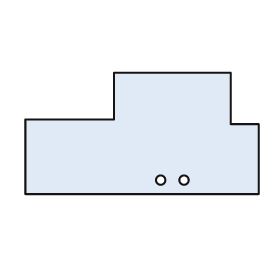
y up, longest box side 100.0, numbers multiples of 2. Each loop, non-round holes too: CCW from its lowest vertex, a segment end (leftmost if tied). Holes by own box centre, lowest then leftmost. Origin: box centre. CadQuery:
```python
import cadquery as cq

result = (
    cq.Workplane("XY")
    .moveTo(-50.0, -26.0)
    .lineTo(50.0, -26.0)
    .lineTo(50.0, 4.0)
    .lineTo(38.0, 4.0)
    .lineTo(38.0, 26.0)
    .lineTo(-12.0, 26.0)
    .lineTo(-12.0, 6.0)
    .lineTo(-50.0, 6.0)
    .close()
    .moveTo(8.0, -20.0)
    .circle(2.0)
    .moveTo(18.0, -20.0)
    .circle(2.0)
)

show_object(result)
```